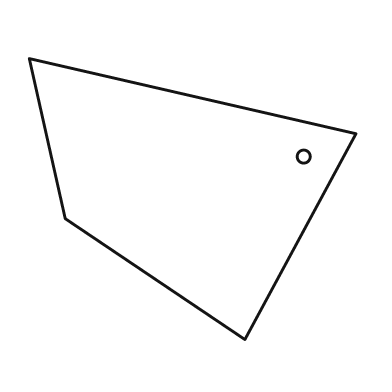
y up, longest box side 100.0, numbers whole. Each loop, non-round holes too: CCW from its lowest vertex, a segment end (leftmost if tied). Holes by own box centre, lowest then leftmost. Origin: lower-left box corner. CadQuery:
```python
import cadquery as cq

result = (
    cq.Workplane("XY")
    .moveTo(66.0, 0.0)
    .lineTo(100.0, 63.0)
    .lineTo(0.0, 86.0)
    .lineTo(11.0, 37.0)
    .close()
    .moveTo(84.0, 56.0)
    .circle(2.0)
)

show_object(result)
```